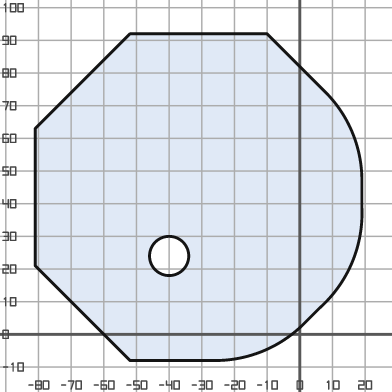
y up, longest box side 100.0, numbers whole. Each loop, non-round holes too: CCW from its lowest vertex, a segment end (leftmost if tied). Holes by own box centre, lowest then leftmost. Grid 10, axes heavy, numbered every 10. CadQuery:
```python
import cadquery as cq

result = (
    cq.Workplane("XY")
    .moveTo(-52.0, -8.0)
    .lineTo(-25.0, -8.0)
    .threePointArc((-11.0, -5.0), (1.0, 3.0))
    .lineTo(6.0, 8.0)
    .threePointArc((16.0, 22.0), (19.0, 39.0))
    .lineTo(19.0, 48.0)
    .threePointArc((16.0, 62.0), (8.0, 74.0))
    .lineTo(-10.0, 92.0)
    .lineTo(-52.0, 92.0)
    .lineTo(-81.0, 63.0)
    .lineTo(-81.0, 21.0)
    .close()
    .moveTo(-40.0, 24.0)
    .circle(6.0)
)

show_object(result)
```